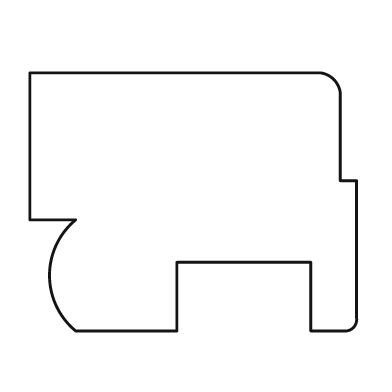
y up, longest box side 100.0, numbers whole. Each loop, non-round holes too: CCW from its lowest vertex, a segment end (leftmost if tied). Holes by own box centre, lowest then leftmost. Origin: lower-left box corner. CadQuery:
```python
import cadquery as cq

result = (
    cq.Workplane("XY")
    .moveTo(14.0, 0.0)
    .lineTo(45.0, 0.0)
    .lineTo(45.0, 21.0)
    .lineTo(86.0, 21.0)
    .lineTo(86.0, 0.0)
    .lineTo(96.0, 0.0)
    .threePointArc((99.0, 1.0), (100.0, 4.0))
    .lineTo(100.0, 46.0)
    .lineTo(95.0, 46.0)
    .lineTo(95.0, 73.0)
    .threePointArc((93.0, 77.0), (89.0, 79.0))
    .lineTo(0.0, 79.0)
    .lineTo(0.0, 34.0)
    .lineTo(14.0, 34.0)
    .threePointArc((6.0, 17.0), (14.0, 0.0))
    .close()
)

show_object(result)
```